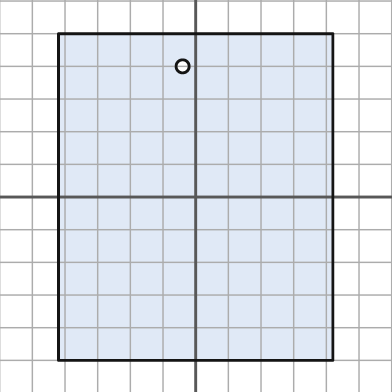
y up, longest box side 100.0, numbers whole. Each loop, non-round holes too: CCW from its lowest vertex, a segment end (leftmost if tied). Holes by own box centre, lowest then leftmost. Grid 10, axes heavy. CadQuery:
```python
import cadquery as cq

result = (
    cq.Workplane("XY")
    .moveTo(-42.0, -50.0)
    .lineTo(42.0, -50.0)
    .lineTo(42.0, 50.0)
    .lineTo(-42.0, 50.0)
    .close()
    .moveTo(-4.0, 40.0)
    .circle(2.0)
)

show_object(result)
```